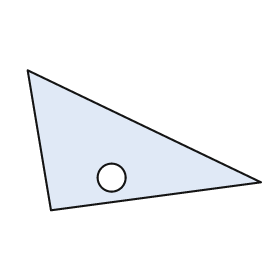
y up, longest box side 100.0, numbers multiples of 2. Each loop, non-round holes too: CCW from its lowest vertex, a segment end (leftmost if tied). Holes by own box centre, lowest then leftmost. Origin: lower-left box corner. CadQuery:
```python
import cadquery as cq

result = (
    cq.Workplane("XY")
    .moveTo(10.0, 0.0)
    .lineTo(100.0, 12.0)
    .lineTo(0.0, 60.0)
    .close()
    .moveTo(36.0, 14.0)
    .circle(6.0)
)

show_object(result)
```